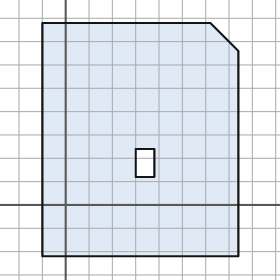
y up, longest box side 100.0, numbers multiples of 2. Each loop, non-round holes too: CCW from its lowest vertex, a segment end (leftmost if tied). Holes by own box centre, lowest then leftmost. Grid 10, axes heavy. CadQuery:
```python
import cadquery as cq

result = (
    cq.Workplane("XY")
    .moveTo(-10.0, -22.0)
    .lineTo(74.0, -22.0)
    .lineTo(74.0, 66.0)
    .lineTo(62.0, 78.0)
    .lineTo(-10.0, 78.0)
    .close()
    .moveTo(30.0, 12.0)
    .lineTo(38.0, 12.0)
    .lineTo(38.0, 24.0)
    .lineTo(30.0, 24.0)
    .close()
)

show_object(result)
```